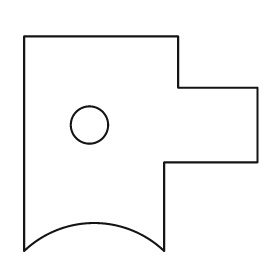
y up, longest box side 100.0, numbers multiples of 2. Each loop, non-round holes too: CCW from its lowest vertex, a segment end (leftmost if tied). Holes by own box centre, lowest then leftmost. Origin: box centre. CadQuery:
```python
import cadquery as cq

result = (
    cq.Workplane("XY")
    .moveTo(-50.0, -46.0)
    .threePointArc((-20.0, -34.0), (10.0, -46.0))
    .lineTo(10.0, -8.0)
    .lineTo(50.0, -8.0)
    .lineTo(50.0, 24.0)
    .lineTo(16.0, 24.0)
    .lineTo(16.0, 46.0)
    .lineTo(-50.0, 46.0)
    .close()
    .moveTo(-22.0, 8.0)
    .circle(8.0)
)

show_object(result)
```